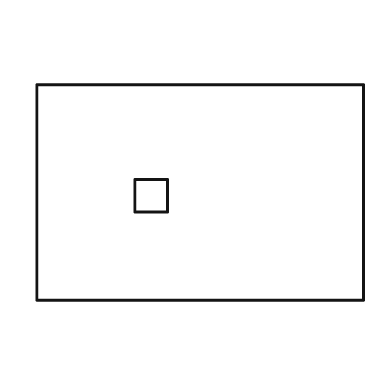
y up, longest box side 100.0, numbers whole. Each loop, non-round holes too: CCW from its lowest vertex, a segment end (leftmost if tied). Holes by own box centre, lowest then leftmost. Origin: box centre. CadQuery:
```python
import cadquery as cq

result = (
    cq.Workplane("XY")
    .moveTo(-50.0, -33.0)
    .lineTo(50.0, -33.0)
    .lineTo(50.0, 33.0)
    .lineTo(-50.0, 33.0)
    .close()
    .moveTo(-20.0, -6.0)
    .lineTo(-10.0, -6.0)
    .lineTo(-10.0, 4.0)
    .lineTo(-20.0, 4.0)
    .close()
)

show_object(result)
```